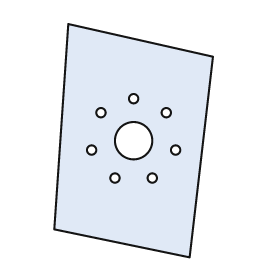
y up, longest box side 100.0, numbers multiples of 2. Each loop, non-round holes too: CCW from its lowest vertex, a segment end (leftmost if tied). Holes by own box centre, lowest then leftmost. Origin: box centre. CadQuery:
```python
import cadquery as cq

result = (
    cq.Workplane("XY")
    .moveTo(24.0, -50.0)
    .lineTo(34.0, 36.0)
    .lineTo(-28.0, 50.0)
    .lineTo(-34.0, -38.0)
    .close()
    .moveTo(-8.0, -16.0)
    .circle(2.0)
    .moveTo(8.0, -16.0)
    .circle(2.0)
    .moveTo(-18.0, -4.0)
    .circle(2.0)
    .moveTo(18.0, -4.0)
    .circle(2.0)
    .moveTo(0.0, 0.0)
    .circle(8.0)
    .moveTo(-14.0, 12.0)
    .circle(2.0)
    .moveTo(14.0, 12.0)
    .circle(2.0)
    .moveTo(0.0, 18.0)
    .circle(2.0)
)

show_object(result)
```